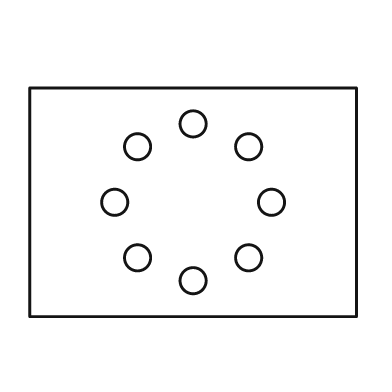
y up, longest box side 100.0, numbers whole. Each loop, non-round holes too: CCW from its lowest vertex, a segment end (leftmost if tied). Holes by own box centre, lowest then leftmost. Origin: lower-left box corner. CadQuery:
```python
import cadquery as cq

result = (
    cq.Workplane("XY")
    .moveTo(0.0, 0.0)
    .lineTo(100.0, 0.0)
    .lineTo(100.0, 70.0)
    .lineTo(0.0, 70.0)
    .close()
    .moveTo(50.0, 11.0)
    .circle(4.0)
    .moveTo(33.0, 18.0)
    .circle(4.0)
    .moveTo(67.0, 18.0)
    .circle(4.0)
    .moveTo(26.0, 35.0)
    .circle(4.0)
    .moveTo(74.0, 35.0)
    .circle(4.0)
    .moveTo(33.0, 52.0)
    .circle(4.0)
    .moveTo(67.0, 52.0)
    .circle(4.0)
    .moveTo(50.0, 59.0)
    .circle(4.0)
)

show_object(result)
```